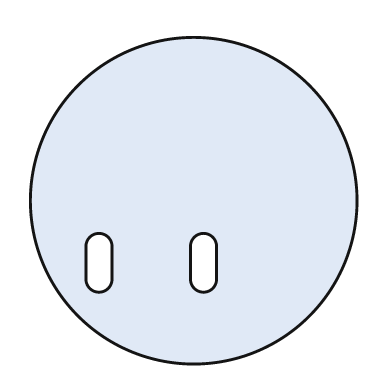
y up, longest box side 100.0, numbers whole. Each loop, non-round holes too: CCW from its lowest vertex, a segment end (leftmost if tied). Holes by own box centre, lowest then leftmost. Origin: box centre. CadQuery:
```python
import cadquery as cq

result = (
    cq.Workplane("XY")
    .moveTo(0.0, 0.0)
    .circle(50.0)
    .moveTo(-33.0, -24.0)
    .threePointArc((-29.0, -28.0), (-25.0, -24.0))
    .lineTo(-25.0, -14.0)
    .threePointArc((-29.0, -10.0), (-33.0, -14.0))
    .close()
    .moveTo(-1.0, -24.0)
    .threePointArc((3.0, -28.0), (7.0, -24.0))
    .lineTo(7.0, -14.0)
    .threePointArc((3.0, -10.0), (-1.0, -14.0))
    .close()
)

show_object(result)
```